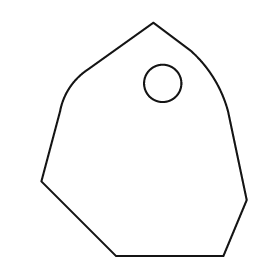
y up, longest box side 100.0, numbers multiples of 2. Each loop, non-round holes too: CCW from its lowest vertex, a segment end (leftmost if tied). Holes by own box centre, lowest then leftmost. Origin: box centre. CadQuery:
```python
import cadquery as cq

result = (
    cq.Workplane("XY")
    .moveTo(-12.0, -50.0)
    .lineTo(34.0, -50.0)
    .lineTo(44.0, -26.0)
    .lineTo(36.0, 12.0)
    .threePointArc((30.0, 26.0), (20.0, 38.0))
    .lineTo(4.0, 50.0)
    .lineTo(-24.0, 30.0)
    .threePointArc((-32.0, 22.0), (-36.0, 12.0))
    .lineTo(-44.0, -18.0)
    .close()
    .moveTo(8.0, 24.0)
    .circle(8.0)
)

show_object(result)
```